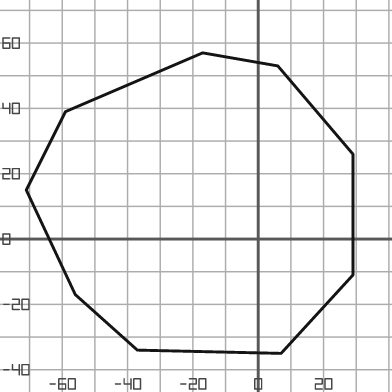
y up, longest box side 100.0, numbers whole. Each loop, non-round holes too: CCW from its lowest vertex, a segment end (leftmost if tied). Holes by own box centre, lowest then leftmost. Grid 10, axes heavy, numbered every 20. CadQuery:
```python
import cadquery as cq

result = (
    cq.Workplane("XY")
    .moveTo(7.0, -35.0)
    .lineTo(29.0, -11.0)
    .lineTo(29.0, 26.0)
    .lineTo(6.0, 53.0)
    .lineTo(-17.0, 57.0)
    .lineTo(-59.0, 39.0)
    .lineTo(-71.0, 15.0)
    .lineTo(-56.0, -17.0)
    .lineTo(-37.0, -34.0)
    .close()
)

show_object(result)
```